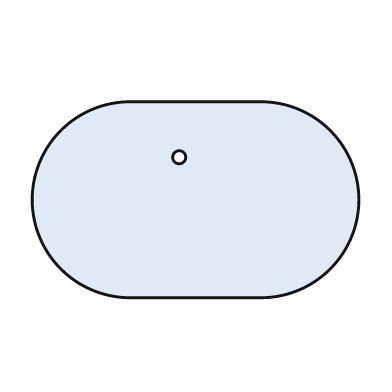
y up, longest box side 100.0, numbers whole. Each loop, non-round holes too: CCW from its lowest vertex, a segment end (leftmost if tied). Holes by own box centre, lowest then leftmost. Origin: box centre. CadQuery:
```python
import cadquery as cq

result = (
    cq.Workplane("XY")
    .moveTo(-20.0, -30.0)
    .lineTo(20.0, -30.0)
    .threePointArc((50.0, 0.0), (20.0, 30.0))
    .lineTo(-20.0, 30.0)
    .threePointArc((-50.0, 0.0), (-20.0, -30.0))
    .close()
    .moveTo(-5.0, 13.0)
    .circle(2.0)
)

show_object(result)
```